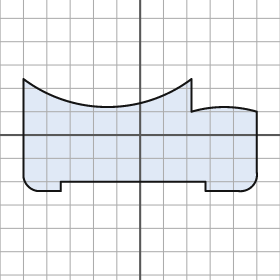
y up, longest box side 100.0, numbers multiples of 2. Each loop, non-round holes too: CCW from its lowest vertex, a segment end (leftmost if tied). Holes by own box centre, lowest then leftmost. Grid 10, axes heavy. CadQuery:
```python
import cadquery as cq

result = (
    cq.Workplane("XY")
    .moveTo(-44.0, -24.0)
    .lineTo(-34.0, -24.0)
    .lineTo(-34.0, -20.0)
    .lineTo(28.0, -20.0)
    .lineTo(28.0, -24.0)
    .lineTo(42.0, -24.0)
    .threePointArc((48.0, -22.0), (50.0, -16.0))
    .lineTo(50.0, 10.0)
    .threePointArc((36.0, 12.0), (22.0, 10.0))
    .lineTo(22.0, 24.0)
    .threePointArc((-14.0, 12.0), (-50.0, 24.0))
    .lineTo(-50.0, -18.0)
    .threePointArc((-48.0, -22.0), (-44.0, -24.0))
    .close()
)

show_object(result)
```